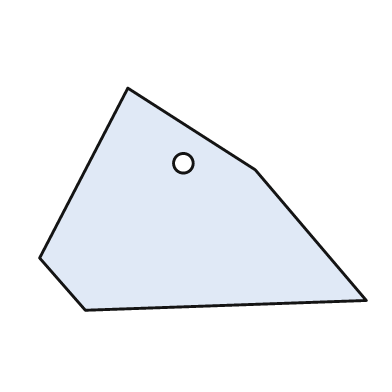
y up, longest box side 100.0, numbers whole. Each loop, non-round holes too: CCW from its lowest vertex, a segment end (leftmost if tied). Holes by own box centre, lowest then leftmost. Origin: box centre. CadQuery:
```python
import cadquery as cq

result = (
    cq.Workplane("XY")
    .moveTo(-36.0, -34.0)
    .lineTo(50.0, -31.0)
    .lineTo(16.0, 9.0)
    .lineTo(-23.0, 34.0)
    .lineTo(-50.0, -18.0)
    .close()
    .moveTo(-6.0, 11.0)
    .circle(3.0)
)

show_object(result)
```